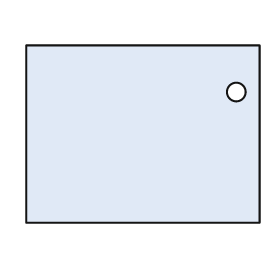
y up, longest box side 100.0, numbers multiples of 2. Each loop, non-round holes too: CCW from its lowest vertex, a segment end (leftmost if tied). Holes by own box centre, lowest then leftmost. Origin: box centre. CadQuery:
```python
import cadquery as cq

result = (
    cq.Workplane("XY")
    .moveTo(-50.0, -38.0)
    .lineTo(50.0, -38.0)
    .lineTo(50.0, 38.0)
    .lineTo(-50.0, 38.0)
    .close()
    .moveTo(40.0, 18.0)
    .circle(4.0)
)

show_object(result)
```